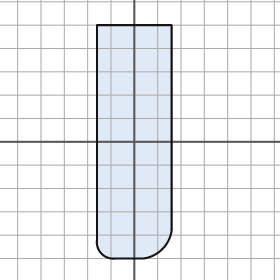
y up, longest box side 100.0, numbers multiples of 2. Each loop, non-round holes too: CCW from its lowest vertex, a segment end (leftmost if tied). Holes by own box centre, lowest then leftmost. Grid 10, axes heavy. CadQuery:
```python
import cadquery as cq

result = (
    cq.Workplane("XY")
    .moveTo(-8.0, -50.0)
    .lineTo(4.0, -50.0)
    .threePointArc((12.0, -46.0), (16.0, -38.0))
    .lineTo(16.0, 50.0)
    .lineTo(-16.0, 50.0)
    .lineTo(-16.0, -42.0)
    .threePointArc((-14.0, -48.0), (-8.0, -50.0))
    .close()
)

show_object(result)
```